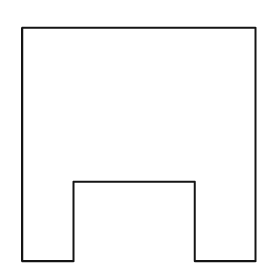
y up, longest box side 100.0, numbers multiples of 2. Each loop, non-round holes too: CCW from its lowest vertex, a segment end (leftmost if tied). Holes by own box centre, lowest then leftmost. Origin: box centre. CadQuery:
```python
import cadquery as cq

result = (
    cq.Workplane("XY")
    .moveTo(-50.0, -50.0)
    .lineTo(-28.0, -50.0)
    .lineTo(-28.0, -16.0)
    .lineTo(24.0, -16.0)
    .lineTo(24.0, -50.0)
    .lineTo(50.0, -50.0)
    .lineTo(50.0, 50.0)
    .lineTo(-50.0, 50.0)
    .close()
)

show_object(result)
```